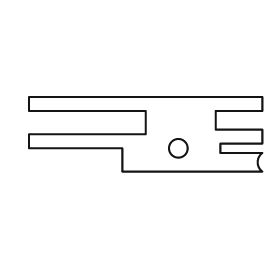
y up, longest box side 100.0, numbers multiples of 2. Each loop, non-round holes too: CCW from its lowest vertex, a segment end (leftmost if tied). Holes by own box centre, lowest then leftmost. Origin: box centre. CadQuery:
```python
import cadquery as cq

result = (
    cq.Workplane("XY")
    .moveTo(-10.0, -16.0)
    .lineTo(50.0, -16.0)
    .threePointArc((48.0, -12.0), (50.0, -8.0))
    .lineTo(32.0, -8.0)
    .lineTo(32.0, -4.0)
    .lineTo(50.0, -4.0)
    .lineTo(50.0, 2.0)
    .lineTo(30.0, 2.0)
    .lineTo(30.0, 10.0)
    .lineTo(50.0, 10.0)
    .lineTo(50.0, 16.0)
    .lineTo(-50.0, 16.0)
    .lineTo(-50.0, 10.0)
    .lineTo(0.0, 10.0)
    .lineTo(0.0, 0.0)
    .lineTo(-50.0, 0.0)
    .lineTo(-50.0, -6.0)
    .lineTo(-10.0, -6.0)
    .close()
    .moveTo(14.0, -6.0)
    .circle(4.0)
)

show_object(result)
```